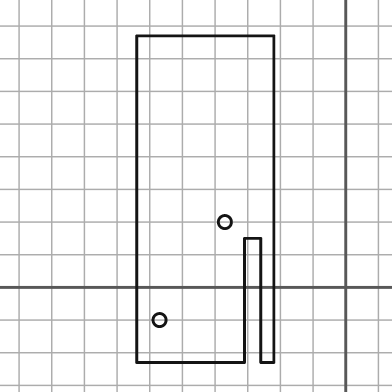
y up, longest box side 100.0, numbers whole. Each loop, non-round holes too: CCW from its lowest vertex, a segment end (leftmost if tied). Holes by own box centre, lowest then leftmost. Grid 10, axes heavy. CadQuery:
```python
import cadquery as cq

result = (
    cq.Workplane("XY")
    .moveTo(-64.0, -23.0)
    .lineTo(-31.0, -23.0)
    .lineTo(-31.0, 15.0)
    .lineTo(-26.0, 15.0)
    .lineTo(-26.0, -23.0)
    .lineTo(-22.0, -23.0)
    .lineTo(-22.0, 77.0)
    .lineTo(-64.0, 77.0)
    .close()
    .moveTo(-57.0, -10.0)
    .circle(2.0)
    .moveTo(-37.0, 20.0)
    .circle(2.0)
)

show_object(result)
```